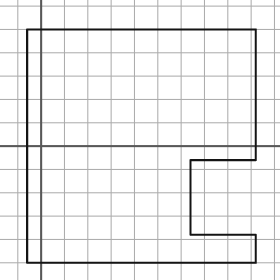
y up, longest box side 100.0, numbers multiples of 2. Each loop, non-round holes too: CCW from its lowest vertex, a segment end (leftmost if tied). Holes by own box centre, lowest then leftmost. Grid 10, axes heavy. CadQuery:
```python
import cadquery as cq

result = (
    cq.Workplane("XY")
    .moveTo(-6.0, -50.0)
    .lineTo(92.0, -50.0)
    .lineTo(92.0, -38.0)
    .lineTo(64.0, -38.0)
    .lineTo(64.0, -6.0)
    .lineTo(92.0, -6.0)
    .lineTo(92.0, 50.0)
    .lineTo(-6.0, 50.0)
    .close()
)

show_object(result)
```